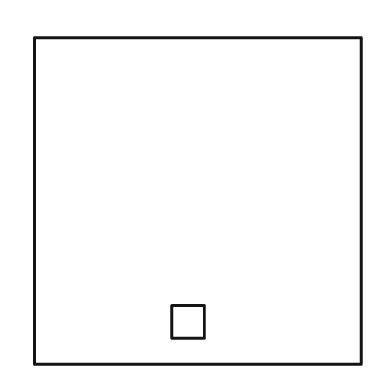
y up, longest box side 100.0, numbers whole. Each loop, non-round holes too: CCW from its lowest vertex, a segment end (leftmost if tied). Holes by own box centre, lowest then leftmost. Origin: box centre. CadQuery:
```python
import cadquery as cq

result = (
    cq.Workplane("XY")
    .moveTo(-50.0, -50.0)
    .lineTo(50.0, -50.0)
    .lineTo(50.0, 50.0)
    .lineTo(-50.0, 50.0)
    .close()
    .moveTo(-8.0, -42.0)
    .lineTo(2.0, -42.0)
    .lineTo(2.0, -32.0)
    .lineTo(-8.0, -32.0)
    .close()
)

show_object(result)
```